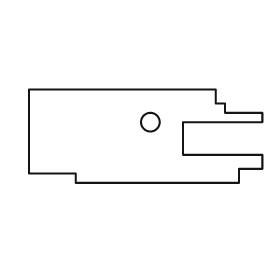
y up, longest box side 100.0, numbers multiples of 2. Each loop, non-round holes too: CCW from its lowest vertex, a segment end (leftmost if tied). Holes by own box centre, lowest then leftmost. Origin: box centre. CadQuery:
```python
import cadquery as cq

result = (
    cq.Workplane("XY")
    .moveTo(-30.0, -20.0)
    .lineTo(40.0, -20.0)
    .lineTo(40.0, -14.0)
    .lineTo(50.0, -14.0)
    .lineTo(50.0, -8.0)
    .lineTo(16.0, -8.0)
    .lineTo(16.0, 6.0)
    .lineTo(50.0, 6.0)
    .lineTo(50.0, 10.0)
    .lineTo(34.0, 10.0)
    .lineTo(34.0, 14.0)
    .lineTo(30.0, 14.0)
    .lineTo(30.0, 20.0)
    .lineTo(-50.0, 20.0)
    .lineTo(-50.0, -16.0)
    .lineTo(-30.0, -16.0)
    .close()
    .moveTo(2.0, 6.0)
    .circle(4.0)
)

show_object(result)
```